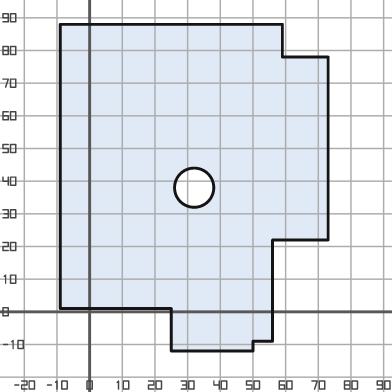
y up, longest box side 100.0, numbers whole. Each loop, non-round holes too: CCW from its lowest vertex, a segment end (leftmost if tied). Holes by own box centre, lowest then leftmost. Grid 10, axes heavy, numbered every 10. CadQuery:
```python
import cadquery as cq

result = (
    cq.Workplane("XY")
    .moveTo(25.0, -12.0)
    .lineTo(50.0, -12.0)
    .lineTo(50.0, -9.0)
    .lineTo(56.0, -9.0)
    .lineTo(56.0, 22.0)
    .lineTo(73.0, 22.0)
    .lineTo(73.0, 78.0)
    .lineTo(59.0, 78.0)
    .lineTo(59.0, 88.0)
    .lineTo(-9.0, 88.0)
    .lineTo(-9.0, 1.0)
    .lineTo(25.0, 1.0)
    .close()
    .moveTo(32.0, 38.0)
    .circle(6.0)
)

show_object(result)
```